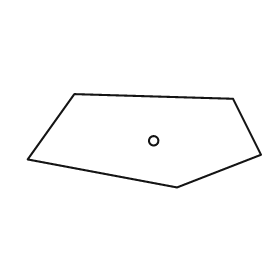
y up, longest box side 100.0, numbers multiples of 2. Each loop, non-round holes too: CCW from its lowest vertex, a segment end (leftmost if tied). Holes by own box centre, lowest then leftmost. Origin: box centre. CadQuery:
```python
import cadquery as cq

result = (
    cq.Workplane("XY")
    .moveTo(14.0, -20.0)
    .lineTo(50.0, -6.0)
    .lineTo(38.0, 18.0)
    .lineTo(-30.0, 20.0)
    .lineTo(-50.0, -8.0)
    .close()
    .moveTo(4.0, 0.0)
    .circle(2.0)
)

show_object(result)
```